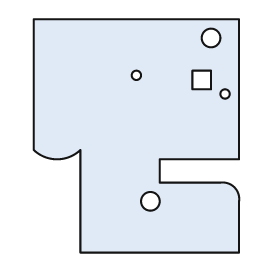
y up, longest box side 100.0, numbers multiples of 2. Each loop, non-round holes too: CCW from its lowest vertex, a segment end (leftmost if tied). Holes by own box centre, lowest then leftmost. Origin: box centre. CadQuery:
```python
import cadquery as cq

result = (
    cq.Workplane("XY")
    .moveTo(-24.0, -50.0)
    .lineTo(44.0, -50.0)
    .lineTo(44.0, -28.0)
    .threePointArc((42.0, -22.0), (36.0, -20.0))
    .lineTo(10.0, -20.0)
    .lineTo(10.0, -10.0)
    .lineTo(44.0, -10.0)
    .lineTo(44.0, 50.0)
    .lineTo(-44.0, 50.0)
    .lineTo(-44.0, -6.0)
    .threePointArc((-34.0, -10.0), (-24.0, -6.0))
    .close()
    .moveTo(6.0, -28.0)
    .circle(4.0)
    .moveTo(38.0, 18.0)
    .circle(2.0)
    .moveTo(24.0, 20.0)
    .lineTo(32.0, 20.0)
    .lineTo(32.0, 28.0)
    .lineTo(24.0, 28.0)
    .close()
    .moveTo(0.0, 26.0)
    .circle(2.0)
    .moveTo(32.0, 42.0)
    .circle(4.0)
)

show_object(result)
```